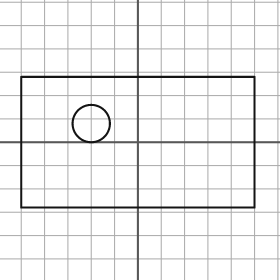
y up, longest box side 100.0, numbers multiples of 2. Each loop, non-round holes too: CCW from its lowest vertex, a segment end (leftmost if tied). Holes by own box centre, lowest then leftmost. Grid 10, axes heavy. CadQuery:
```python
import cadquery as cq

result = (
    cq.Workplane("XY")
    .moveTo(-50.0, -28.0)
    .lineTo(50.0, -28.0)
    .lineTo(50.0, 28.0)
    .lineTo(-50.0, 28.0)
    .close()
    .moveTo(-20.0, 8.0)
    .circle(8.0)
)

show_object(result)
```